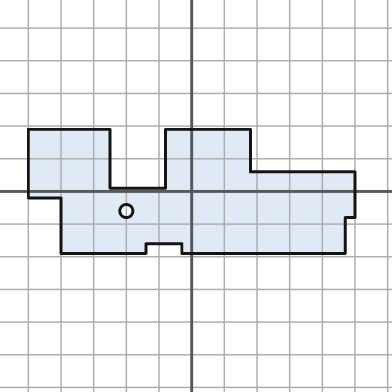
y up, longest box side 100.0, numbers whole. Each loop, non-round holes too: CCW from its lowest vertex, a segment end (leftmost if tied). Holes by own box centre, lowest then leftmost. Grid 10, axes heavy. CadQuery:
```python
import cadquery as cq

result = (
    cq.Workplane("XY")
    .moveTo(-40.0, -19.0)
    .lineTo(-14.0, -19.0)
    .lineTo(-14.0, -16.0)
    .lineTo(-3.0, -16.0)
    .lineTo(-3.0, -19.0)
    .lineTo(47.0, -19.0)
    .lineTo(47.0, -8.0)
    .lineTo(50.0, -8.0)
    .lineTo(50.0, 6.0)
    .lineTo(18.0, 6.0)
    .lineTo(18.0, 19.0)
    .lineTo(-8.0, 19.0)
    .lineTo(-8.0, 1.0)
    .lineTo(-25.0, 1.0)
    .lineTo(-25.0, 19.0)
    .lineTo(-50.0, 19.0)
    .lineTo(-50.0, -2.0)
    .lineTo(-40.0, -2.0)
    .close()
    .moveTo(-20.0, -6.0)
    .circle(2.0)
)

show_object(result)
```